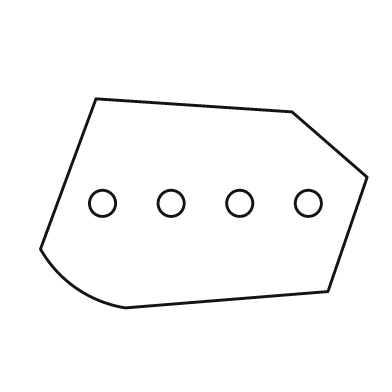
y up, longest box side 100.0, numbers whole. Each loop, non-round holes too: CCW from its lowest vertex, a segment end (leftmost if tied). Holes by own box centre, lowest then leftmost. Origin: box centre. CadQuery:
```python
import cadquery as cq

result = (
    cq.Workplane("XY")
    .moveTo(-24.0, -32.0)
    .lineTo(38.0, -27.0)
    .lineTo(50.0, 8.0)
    .lineTo(27.0, 28.0)
    .lineTo(-33.0, 32.0)
    .lineTo(-50.0, -14.0)
    .threePointArc((-39.0, -26.0), (-24.0, -32.0))
    .close()
    .moveTo(-31.0, 0.0)
    .circle(4.0)
    .moveTo(-10.0, 0.0)
    .circle(4.0)
    .moveTo(11.0, 0.0)
    .circle(4.0)
    .moveTo(32.0, 0.0)
    .circle(4.0)
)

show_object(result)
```